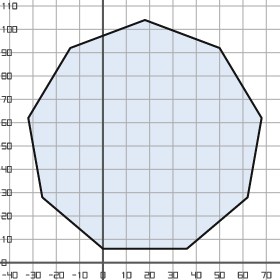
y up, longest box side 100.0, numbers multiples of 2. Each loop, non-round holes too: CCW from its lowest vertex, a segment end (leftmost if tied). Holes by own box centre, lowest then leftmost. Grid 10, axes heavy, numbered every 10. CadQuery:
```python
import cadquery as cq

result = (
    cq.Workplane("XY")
    .moveTo(0.0, 6.0)
    .lineTo(36.0, 6.0)
    .lineTo(62.0, 28.0)
    .lineTo(68.0, 62.0)
    .lineTo(50.0, 92.0)
    .lineTo(18.0, 104.0)
    .lineTo(-14.0, 92.0)
    .lineTo(-32.0, 62.0)
    .lineTo(-26.0, 28.0)
    .close()
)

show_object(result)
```